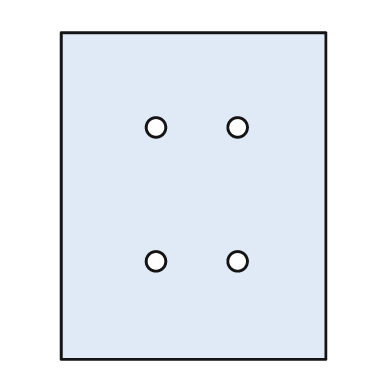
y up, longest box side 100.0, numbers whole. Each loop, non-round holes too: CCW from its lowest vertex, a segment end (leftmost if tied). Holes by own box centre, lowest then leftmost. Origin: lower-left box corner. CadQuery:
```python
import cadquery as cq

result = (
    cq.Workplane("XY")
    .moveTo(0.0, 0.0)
    .lineTo(81.0, 0.0)
    .lineTo(81.0, 100.0)
    .lineTo(0.0, 100.0)
    .close()
    .moveTo(29.0, 30.0)
    .circle(3.0)
    .moveTo(54.0, 30.0)
    .circle(3.0)
    .moveTo(29.0, 71.0)
    .circle(3.0)
    .moveTo(54.0, 71.0)
    .circle(3.0)
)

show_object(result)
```